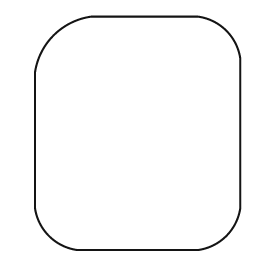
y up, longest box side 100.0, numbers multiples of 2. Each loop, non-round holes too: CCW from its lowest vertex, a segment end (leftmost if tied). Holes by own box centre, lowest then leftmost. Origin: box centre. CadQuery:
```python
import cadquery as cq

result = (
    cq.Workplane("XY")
    .moveTo(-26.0, -50.0)
    .lineTo(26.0, -50.0)
    .threePointArc((38.0, -44.0), (44.0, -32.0))
    .lineTo(44.0, 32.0)
    .threePointArc((38.0, 44.0), (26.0, 50.0))
    .lineTo(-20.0, 50.0)
    .threePointArc((-36.0, 42.0), (-44.0, 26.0))
    .lineTo(-44.0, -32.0)
    .threePointArc((-38.0, -44.0), (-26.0, -50.0))
    .close()
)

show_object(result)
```